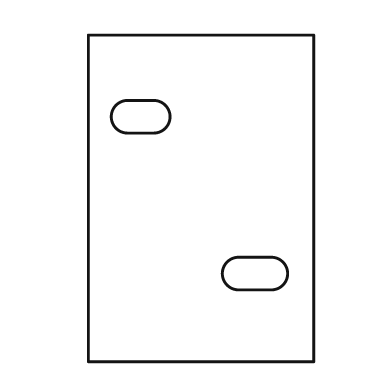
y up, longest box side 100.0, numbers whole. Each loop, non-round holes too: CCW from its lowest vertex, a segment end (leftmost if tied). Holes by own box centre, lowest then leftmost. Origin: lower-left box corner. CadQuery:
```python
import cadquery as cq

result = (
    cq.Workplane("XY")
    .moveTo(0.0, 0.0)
    .lineTo(69.0, 0.0)
    .lineTo(69.0, 100.0)
    .lineTo(0.0, 100.0)
    .close()
    .moveTo(46.0, 22.0)
    .lineTo(56.0, 22.0)
    .threePointArc((61.0, 27.0), (56.0, 32.0))
    .lineTo(46.0, 32.0)
    .threePointArc((41.0, 27.0), (46.0, 22.0))
    .close()
    .moveTo(12.0, 70.0)
    .lineTo(20.0, 70.0)
    .threePointArc((25.0, 75.0), (20.0, 80.0))
    .lineTo(12.0, 80.0)
    .threePointArc((7.0, 75.0), (12.0, 70.0))
    .close()
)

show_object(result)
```